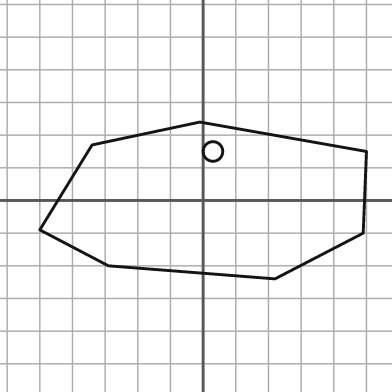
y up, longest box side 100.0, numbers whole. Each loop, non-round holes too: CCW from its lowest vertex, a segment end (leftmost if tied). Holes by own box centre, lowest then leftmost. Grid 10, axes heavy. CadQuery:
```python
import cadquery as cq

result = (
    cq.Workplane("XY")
    .moveTo(22.0, -24.0)
    .lineTo(49.0, -10.0)
    .lineTo(50.0, 15.0)
    .lineTo(-1.0, 24.0)
    .lineTo(-34.0, 17.0)
    .lineTo(-50.0, -9.0)
    .lineTo(-29.0, -20.0)
    .close()
    .moveTo(3.0, 15.0)
    .circle(3.0)
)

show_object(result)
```